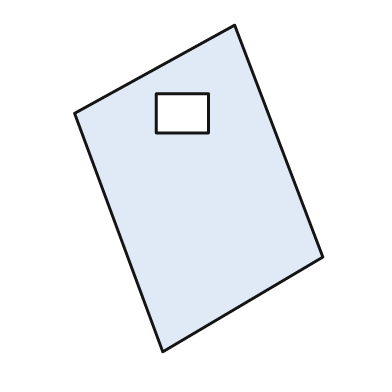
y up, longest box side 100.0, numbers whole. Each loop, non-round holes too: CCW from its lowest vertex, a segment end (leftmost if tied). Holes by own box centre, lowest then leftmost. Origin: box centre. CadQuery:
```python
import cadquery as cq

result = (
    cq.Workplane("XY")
    .moveTo(-11.0, -50.0)
    .lineTo(38.0, -21.0)
    .lineTo(11.0, 50.0)
    .lineTo(-38.0, 23.0)
    .close()
    .moveTo(-13.0, 17.0)
    .lineTo(3.0, 17.0)
    .lineTo(3.0, 29.0)
    .lineTo(-13.0, 29.0)
    .close()
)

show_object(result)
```